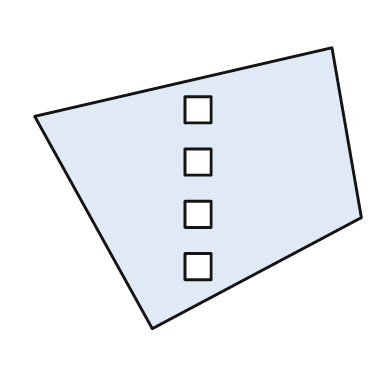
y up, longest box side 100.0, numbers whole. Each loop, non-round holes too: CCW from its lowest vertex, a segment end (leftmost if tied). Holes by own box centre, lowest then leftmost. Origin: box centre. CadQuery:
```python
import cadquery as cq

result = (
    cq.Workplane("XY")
    .moveTo(-14.0, -43.0)
    .lineTo(50.0, -9.0)
    .lineTo(41.0, 43.0)
    .lineTo(-50.0, 22.0)
    .close()
    .moveTo(-4.0, -28.0)
    .lineTo(4.0, -28.0)
    .lineTo(4.0, -20.0)
    .lineTo(-4.0, -20.0)
    .close()
    .moveTo(-4.0, -12.0)
    .lineTo(4.0, -12.0)
    .lineTo(4.0, -4.0)
    .lineTo(-4.0, -4.0)
    .close()
    .moveTo(-4.0, 4.0)
    .lineTo(4.0, 4.0)
    .lineTo(4.0, 12.0)
    .lineTo(-4.0, 12.0)
    .close()
    .moveTo(-4.0, 20.0)
    .lineTo(4.0, 20.0)
    .lineTo(4.0, 28.0)
    .lineTo(-4.0, 28.0)
    .close()
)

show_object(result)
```